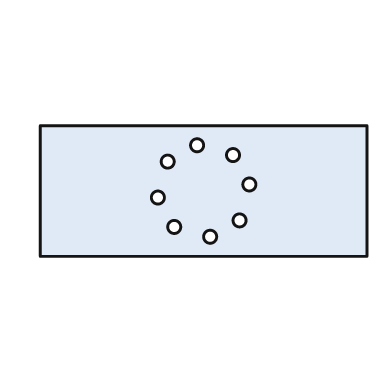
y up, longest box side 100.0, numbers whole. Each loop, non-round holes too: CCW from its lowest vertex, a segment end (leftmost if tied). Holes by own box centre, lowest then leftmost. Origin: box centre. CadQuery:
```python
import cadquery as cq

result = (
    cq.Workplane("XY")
    .moveTo(-50.0, -20.0)
    .lineTo(50.0, -20.0)
    .lineTo(50.0, 20.0)
    .lineTo(-50.0, 20.0)
    .close()
    .moveTo(2.0, -14.0)
    .circle(2.0)
    .moveTo(-9.0, -11.0)
    .circle(2.0)
    .moveTo(11.0, -9.0)
    .circle(2.0)
    .moveTo(-14.0, -2.0)
    .circle(2.0)
    .moveTo(14.0, 2.0)
    .circle(2.0)
    .moveTo(-11.0, 9.0)
    .circle(2.0)
    .moveTo(9.0, 11.0)
    .circle(2.0)
    .moveTo(-2.0, 14.0)
    .circle(2.0)
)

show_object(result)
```